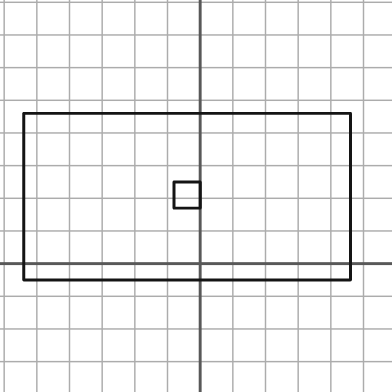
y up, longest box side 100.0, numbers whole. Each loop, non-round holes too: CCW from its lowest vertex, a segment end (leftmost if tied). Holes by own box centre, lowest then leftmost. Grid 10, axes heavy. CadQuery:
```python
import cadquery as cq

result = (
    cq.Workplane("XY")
    .moveTo(-54.0, -5.0)
    .lineTo(46.0, -5.0)
    .lineTo(46.0, 46.0)
    .lineTo(-54.0, 46.0)
    .close()
    .moveTo(-8.0, 17.0)
    .lineTo(0.0, 17.0)
    .lineTo(0.0, 25.0)
    .lineTo(-8.0, 25.0)
    .close()
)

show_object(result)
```